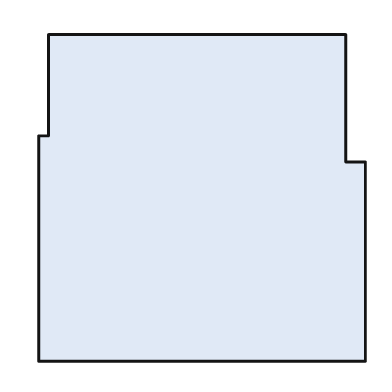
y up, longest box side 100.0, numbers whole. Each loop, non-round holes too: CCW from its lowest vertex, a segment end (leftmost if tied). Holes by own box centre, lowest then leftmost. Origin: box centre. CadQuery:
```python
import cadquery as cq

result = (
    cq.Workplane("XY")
    .moveTo(-50.0, -50.0)
    .lineTo(50.0, -50.0)
    .lineTo(50.0, 11.0)
    .lineTo(44.0, 11.0)
    .lineTo(44.0, 50.0)
    .lineTo(-47.0, 50.0)
    .lineTo(-47.0, 19.0)
    .lineTo(-50.0, 19.0)
    .close()
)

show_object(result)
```